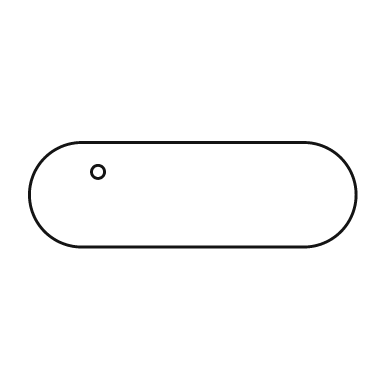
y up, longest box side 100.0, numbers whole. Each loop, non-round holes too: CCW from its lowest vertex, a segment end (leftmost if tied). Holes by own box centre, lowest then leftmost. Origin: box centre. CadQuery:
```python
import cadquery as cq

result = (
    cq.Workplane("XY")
    .moveTo(-34.0, -16.0)
    .lineTo(34.0, -16.0)
    .threePointArc((50.0, 0.0), (34.0, 16.0))
    .lineTo(-34.0, 16.0)
    .threePointArc((-50.0, 0.0), (-34.0, -16.0))
    .close()
    .moveTo(-29.0, 7.0)
    .circle(2.0)
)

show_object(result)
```